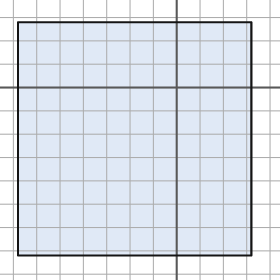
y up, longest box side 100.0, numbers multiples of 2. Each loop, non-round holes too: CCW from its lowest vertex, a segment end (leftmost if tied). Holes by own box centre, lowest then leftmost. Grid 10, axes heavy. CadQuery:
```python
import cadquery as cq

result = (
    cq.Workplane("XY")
    .moveTo(-68.0, -72.0)
    .lineTo(32.0, -72.0)
    .lineTo(32.0, 28.0)
    .lineTo(-68.0, 28.0)
    .close()
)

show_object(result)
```